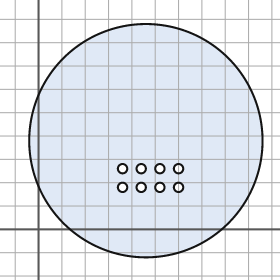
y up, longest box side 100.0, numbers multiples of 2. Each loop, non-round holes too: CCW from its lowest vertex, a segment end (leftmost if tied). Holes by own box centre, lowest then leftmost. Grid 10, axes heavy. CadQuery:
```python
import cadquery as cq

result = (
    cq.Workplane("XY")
    .moveTo(46.0, 38.0)
    .circle(50.0)
    .moveTo(36.0, 18.0)
    .circle(2.0)
    .moveTo(44.0, 18.0)
    .circle(2.0)
    .moveTo(52.0, 18.0)
    .circle(2.0)
    .moveTo(60.0, 18.0)
    .circle(2.0)
    .moveTo(36.0, 26.0)
    .circle(2.0)
    .moveTo(44.0, 26.0)
    .circle(2.0)
    .moveTo(52.0, 26.0)
    .circle(2.0)
    .moveTo(60.0, 26.0)
    .circle(2.0)
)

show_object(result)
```